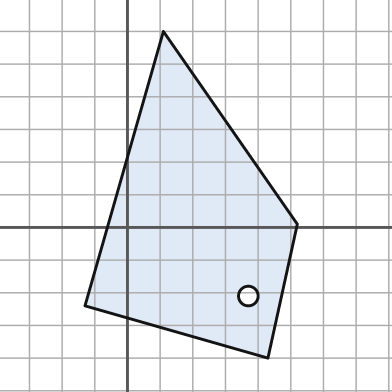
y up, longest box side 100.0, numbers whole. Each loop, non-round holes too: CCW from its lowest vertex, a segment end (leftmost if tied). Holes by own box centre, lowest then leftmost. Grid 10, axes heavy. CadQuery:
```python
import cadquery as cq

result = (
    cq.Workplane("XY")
    .moveTo(43.0, -40.0)
    .lineTo(52.0, 1.0)
    .lineTo(11.0, 60.0)
    .lineTo(-13.0, -24.0)
    .close()
    .moveTo(37.0, -21.0)
    .circle(3.0)
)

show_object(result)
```